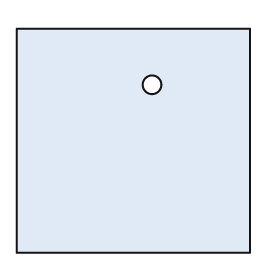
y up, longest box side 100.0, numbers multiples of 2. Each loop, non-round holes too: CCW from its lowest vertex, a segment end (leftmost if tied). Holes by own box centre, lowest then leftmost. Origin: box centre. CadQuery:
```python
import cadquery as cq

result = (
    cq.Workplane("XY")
    .moveTo(-50.0, -48.0)
    .lineTo(50.0, -48.0)
    .lineTo(50.0, 48.0)
    .lineTo(-50.0, 48.0)
    .close()
    .moveTo(8.0, 24.0)
    .circle(4.0)
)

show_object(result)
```